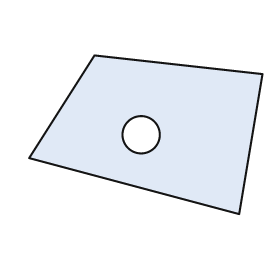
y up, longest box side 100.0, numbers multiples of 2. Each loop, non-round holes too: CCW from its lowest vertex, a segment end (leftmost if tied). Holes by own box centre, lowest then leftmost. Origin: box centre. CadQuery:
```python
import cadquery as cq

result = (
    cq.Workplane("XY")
    .moveTo(40.0, -34.0)
    .lineTo(50.0, 26.0)
    .lineTo(-22.0, 34.0)
    .lineTo(-50.0, -10.0)
    .close()
    .moveTo(-2.0, 0.0)
    .circle(8.0)
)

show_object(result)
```